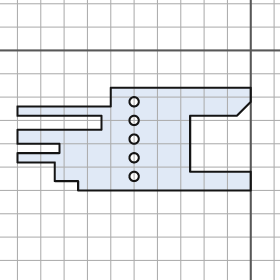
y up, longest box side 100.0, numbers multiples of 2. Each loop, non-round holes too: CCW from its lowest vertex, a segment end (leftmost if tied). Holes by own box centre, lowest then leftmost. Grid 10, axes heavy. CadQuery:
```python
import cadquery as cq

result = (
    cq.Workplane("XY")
    .moveTo(-74.0, -60.0)
    .lineTo(0.0, -60.0)
    .lineTo(0.0, -52.0)
    .lineTo(-26.0, -52.0)
    .lineTo(-26.0, -28.0)
    .lineTo(-6.0, -28.0)
    .lineTo(0.0, -22.0)
    .lineTo(0.0, -16.0)
    .lineTo(-60.0, -16.0)
    .lineTo(-60.0, -24.0)
    .lineTo(-100.0, -24.0)
    .lineTo(-100.0, -28.0)
    .lineTo(-64.0, -28.0)
    .lineTo(-64.0, -34.0)
    .lineTo(-100.0, -34.0)
    .lineTo(-100.0, -40.0)
    .lineTo(-82.0, -40.0)
    .lineTo(-82.0, -44.0)
    .lineTo(-100.0, -44.0)
    .lineTo(-100.0, -48.0)
    .lineTo(-84.0, -48.0)
    .lineTo(-84.0, -56.0)
    .lineTo(-74.0, -56.0)
    .close()
    .moveTo(-50.0, -54.0)
    .circle(2.0)
    .moveTo(-50.0, -46.0)
    .circle(2.0)
    .moveTo(-50.0, -38.0)
    .circle(2.0)
    .moveTo(-50.0, -30.0)
    .circle(2.0)
    .moveTo(-50.0, -22.0)
    .circle(2.0)
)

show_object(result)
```